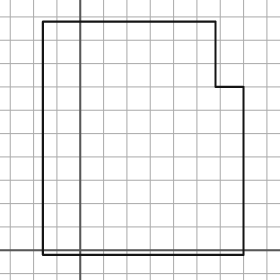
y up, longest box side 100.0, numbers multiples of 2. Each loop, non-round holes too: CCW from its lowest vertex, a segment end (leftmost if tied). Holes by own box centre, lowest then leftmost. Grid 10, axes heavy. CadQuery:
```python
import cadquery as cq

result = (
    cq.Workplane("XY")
    .moveTo(-16.0, -2.0)
    .lineTo(70.0, -2.0)
    .lineTo(70.0, 70.0)
    .lineTo(58.0, 70.0)
    .lineTo(58.0, 98.0)
    .lineTo(-16.0, 98.0)
    .close()
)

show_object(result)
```